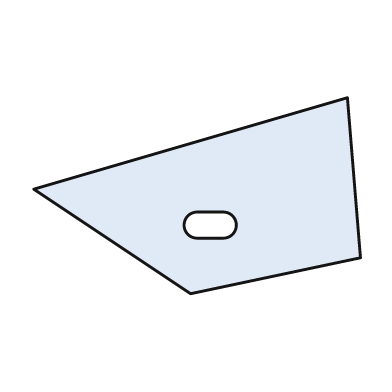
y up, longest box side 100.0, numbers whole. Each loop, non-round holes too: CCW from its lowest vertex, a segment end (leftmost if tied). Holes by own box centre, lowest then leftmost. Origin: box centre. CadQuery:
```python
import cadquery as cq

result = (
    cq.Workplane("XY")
    .moveTo(-2.0, -30.0)
    .lineTo(50.0, -19.0)
    .lineTo(46.0, 30.0)
    .lineTo(-50.0, 2.0)
    .close()
    .moveTo(0.0, -13.0)
    .lineTo(8.0, -13.0)
    .threePointArc((12.0, -9.0), (8.0, -5.0))
    .lineTo(0.0, -5.0)
    .threePointArc((-4.0, -9.0), (0.0, -13.0))
    .close()
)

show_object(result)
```